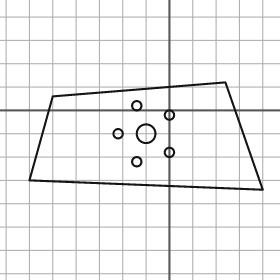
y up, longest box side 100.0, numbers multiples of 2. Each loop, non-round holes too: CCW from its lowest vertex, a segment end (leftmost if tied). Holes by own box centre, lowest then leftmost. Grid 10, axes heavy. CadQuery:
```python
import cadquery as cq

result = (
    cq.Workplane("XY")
    .moveTo(40.0, -34.0)
    .lineTo(24.0, 12.0)
    .lineTo(-50.0, 6.0)
    .lineTo(-60.0, -30.0)
    .close()
    .moveTo(-14.0, -22.0)
    .circle(2.0)
    .moveTo(0.0, -18.0)
    .circle(2.0)
    .moveTo(-22.0, -10.0)
    .circle(2.0)
    .moveTo(-10.0, -10.0)
    .circle(4.0)
    .moveTo(0.0, -2.0)
    .circle(2.0)
    .moveTo(-14.0, 2.0)
    .circle(2.0)
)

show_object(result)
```